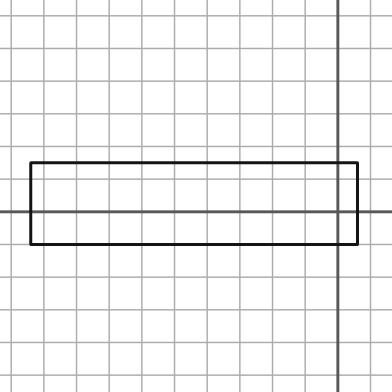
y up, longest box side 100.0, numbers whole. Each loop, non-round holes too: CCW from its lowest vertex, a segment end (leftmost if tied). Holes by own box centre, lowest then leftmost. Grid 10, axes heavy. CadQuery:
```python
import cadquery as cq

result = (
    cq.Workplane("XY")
    .moveTo(-94.0, -10.0)
    .lineTo(6.0, -10.0)
    .lineTo(6.0, 15.0)
    .lineTo(-94.0, 15.0)
    .close()
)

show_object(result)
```